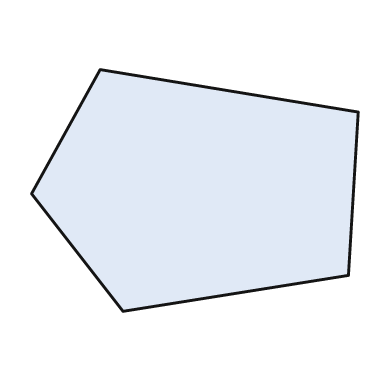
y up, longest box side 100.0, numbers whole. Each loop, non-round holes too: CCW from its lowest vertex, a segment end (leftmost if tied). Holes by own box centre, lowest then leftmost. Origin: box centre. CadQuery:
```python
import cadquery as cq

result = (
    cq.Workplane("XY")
    .moveTo(-22.0, -37.0)
    .lineTo(47.0, -26.0)
    .lineTo(50.0, 24.0)
    .lineTo(-29.0, 37.0)
    .lineTo(-50.0, -1.0)
    .close()
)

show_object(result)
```